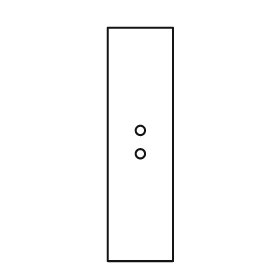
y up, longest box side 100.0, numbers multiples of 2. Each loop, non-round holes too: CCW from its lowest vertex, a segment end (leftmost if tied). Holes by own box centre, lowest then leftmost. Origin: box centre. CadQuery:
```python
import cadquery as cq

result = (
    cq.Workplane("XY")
    .moveTo(-14.0, -50.0)
    .lineTo(14.0, -50.0)
    .lineTo(14.0, 50.0)
    .lineTo(-14.0, 50.0)
    .close()
    .moveTo(0.0, -4.0)
    .circle(2.0)
    .moveTo(0.0, 6.0)
    .circle(2.0)
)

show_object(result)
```